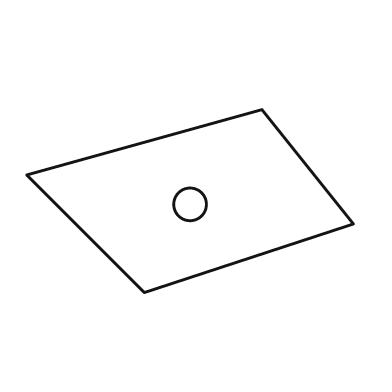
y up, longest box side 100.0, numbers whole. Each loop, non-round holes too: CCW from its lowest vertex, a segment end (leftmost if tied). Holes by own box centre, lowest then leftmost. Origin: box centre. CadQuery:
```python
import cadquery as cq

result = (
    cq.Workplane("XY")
    .moveTo(-14.0, -28.0)
    .lineTo(50.0, -7.0)
    .lineTo(22.0, 28.0)
    .lineTo(-50.0, 8.0)
    .close()
    .moveTo(0.0, -1.0)
    .circle(5.0)
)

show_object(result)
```